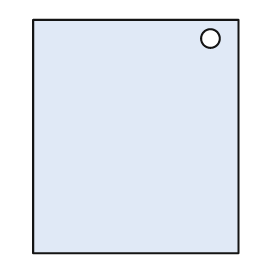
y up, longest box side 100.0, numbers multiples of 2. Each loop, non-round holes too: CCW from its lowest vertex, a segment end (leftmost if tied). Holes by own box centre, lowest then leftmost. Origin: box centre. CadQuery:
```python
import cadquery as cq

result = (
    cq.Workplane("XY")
    .moveTo(-44.0, -50.0)
    .lineTo(44.0, -50.0)
    .lineTo(44.0, 50.0)
    .lineTo(-44.0, 50.0)
    .close()
    .moveTo(32.0, 42.0)
    .circle(4.0)
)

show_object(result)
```